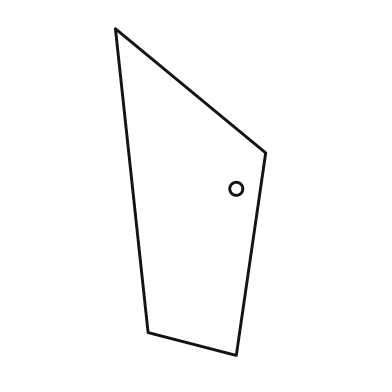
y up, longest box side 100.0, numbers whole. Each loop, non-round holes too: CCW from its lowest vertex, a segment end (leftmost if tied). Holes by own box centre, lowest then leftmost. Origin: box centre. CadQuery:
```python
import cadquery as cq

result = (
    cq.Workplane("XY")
    .moveTo(14.0, -50.0)
    .lineTo(23.0, 12.0)
    .lineTo(-23.0, 50.0)
    .lineTo(-13.0, -43.0)
    .close()
    .moveTo(14.0, 1.0)
    .circle(2.0)
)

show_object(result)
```